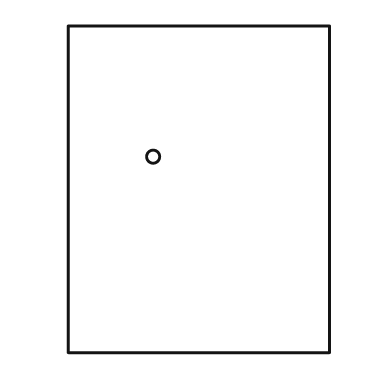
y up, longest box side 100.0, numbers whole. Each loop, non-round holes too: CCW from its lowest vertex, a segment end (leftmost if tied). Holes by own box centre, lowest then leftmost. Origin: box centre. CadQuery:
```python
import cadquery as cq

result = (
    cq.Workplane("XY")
    .moveTo(-40.0, -50.0)
    .lineTo(40.0, -50.0)
    .lineTo(40.0, 50.0)
    .lineTo(-40.0, 50.0)
    .close()
    .moveTo(-14.0, 10.0)
    .circle(2.0)
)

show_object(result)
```